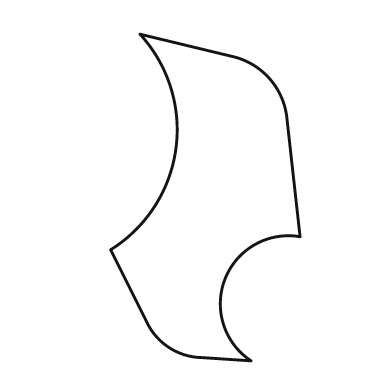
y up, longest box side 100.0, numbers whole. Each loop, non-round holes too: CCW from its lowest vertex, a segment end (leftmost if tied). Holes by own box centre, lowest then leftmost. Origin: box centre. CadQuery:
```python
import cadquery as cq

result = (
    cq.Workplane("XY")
    .moveTo(14.0, -50.0)
    .threePointArc((6.0, -25.0), (29.0, -12.0))
    .lineTo(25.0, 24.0)
    .threePointArc((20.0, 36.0), (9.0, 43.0))
    .lineTo(-20.0, 50.0)
    .threePointArc((-9.0, 15.0), (-29.0, -16.0))
    .lineTo(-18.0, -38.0)
    .threePointArc((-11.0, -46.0), (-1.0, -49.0))
    .close()
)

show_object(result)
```